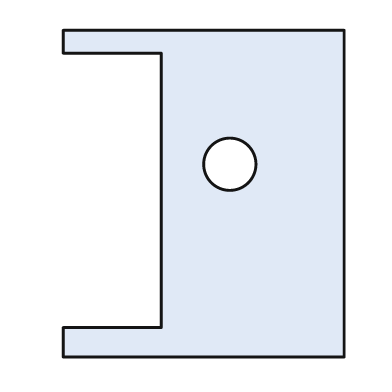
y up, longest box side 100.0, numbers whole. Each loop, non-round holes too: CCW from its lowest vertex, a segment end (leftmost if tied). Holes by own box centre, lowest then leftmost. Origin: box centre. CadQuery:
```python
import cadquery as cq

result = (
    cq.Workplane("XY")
    .moveTo(-43.0, -50.0)
    .lineTo(43.0, -50.0)
    .lineTo(43.0, 50.0)
    .lineTo(-43.0, 50.0)
    .lineTo(-43.0, 43.0)
    .lineTo(-13.0, 43.0)
    .lineTo(-13.0, -41.0)
    .lineTo(-43.0, -41.0)
    .close()
    .moveTo(8.0, 9.0)
    .circle(8.0)
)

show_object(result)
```